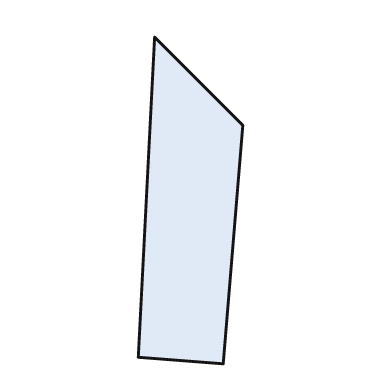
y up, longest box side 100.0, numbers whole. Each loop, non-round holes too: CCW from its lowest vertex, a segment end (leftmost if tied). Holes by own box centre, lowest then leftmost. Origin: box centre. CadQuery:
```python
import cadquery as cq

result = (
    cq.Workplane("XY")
    .moveTo(10.0, -50.0)
    .lineTo(16.0, 23.0)
    .lineTo(-11.0, 50.0)
    .lineTo(-16.0, -48.0)
    .close()
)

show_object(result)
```